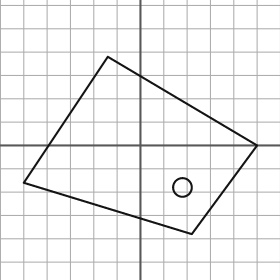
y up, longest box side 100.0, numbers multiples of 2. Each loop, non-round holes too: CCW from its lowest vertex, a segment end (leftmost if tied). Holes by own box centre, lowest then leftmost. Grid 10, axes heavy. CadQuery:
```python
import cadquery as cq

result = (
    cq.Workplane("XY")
    .moveTo(22.0, -38.0)
    .lineTo(50.0, 0.0)
    .lineTo(-14.0, 38.0)
    .lineTo(-50.0, -16.0)
    .close()
    .moveTo(18.0, -18.0)
    .circle(4.0)
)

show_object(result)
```